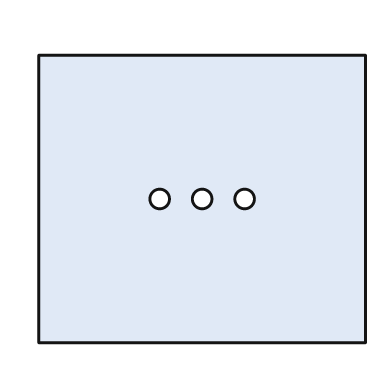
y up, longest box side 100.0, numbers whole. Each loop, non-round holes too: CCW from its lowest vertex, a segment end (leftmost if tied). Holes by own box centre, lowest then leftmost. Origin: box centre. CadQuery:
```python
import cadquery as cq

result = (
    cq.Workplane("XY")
    .moveTo(-50.0, -44.0)
    .lineTo(50.0, -44.0)
    .lineTo(50.0, 44.0)
    .lineTo(-50.0, 44.0)
    .close()
    .moveTo(-13.0, 0.0)
    .circle(3.0)
    .moveTo(0.0, 0.0)
    .circle(3.0)
    .moveTo(13.0, 0.0)
    .circle(3.0)
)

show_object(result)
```